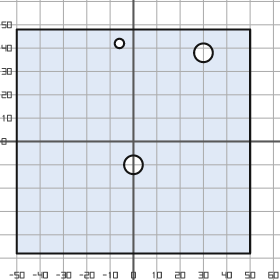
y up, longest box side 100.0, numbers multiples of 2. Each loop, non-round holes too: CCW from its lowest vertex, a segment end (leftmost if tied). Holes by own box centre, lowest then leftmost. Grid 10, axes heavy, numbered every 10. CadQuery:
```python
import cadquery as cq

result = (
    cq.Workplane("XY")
    .moveTo(-50.0, -48.0)
    .lineTo(50.0, -48.0)
    .lineTo(50.0, 48.0)
    .lineTo(-50.0, 48.0)
    .close()
    .moveTo(0.0, -10.0)
    .circle(4.0)
    .moveTo(30.0, 38.0)
    .circle(4.0)
    .moveTo(-6.0, 42.0)
    .circle(2.0)
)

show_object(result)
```